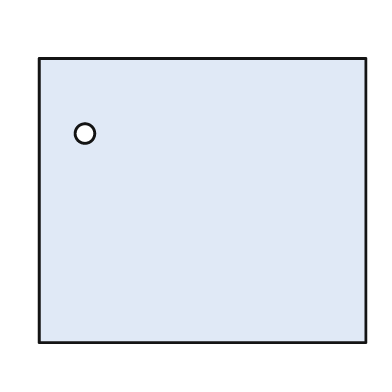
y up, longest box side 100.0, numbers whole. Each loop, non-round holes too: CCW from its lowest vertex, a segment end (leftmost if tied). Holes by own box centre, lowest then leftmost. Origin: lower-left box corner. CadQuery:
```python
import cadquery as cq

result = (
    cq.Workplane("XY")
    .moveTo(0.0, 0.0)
    .lineTo(100.0, 0.0)
    .lineTo(100.0, 87.0)
    .lineTo(0.0, 87.0)
    .close()
    .moveTo(14.0, 64.0)
    .circle(3.0)
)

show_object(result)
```